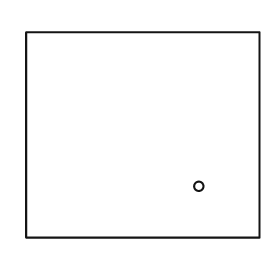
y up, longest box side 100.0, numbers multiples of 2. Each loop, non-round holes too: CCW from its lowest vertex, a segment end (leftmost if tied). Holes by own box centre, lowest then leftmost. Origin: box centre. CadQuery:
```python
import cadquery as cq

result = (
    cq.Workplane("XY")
    .moveTo(-50.0, -44.0)
    .lineTo(50.0, -44.0)
    .lineTo(50.0, 44.0)
    .lineTo(-50.0, 44.0)
    .close()
    .moveTo(24.0, -22.0)
    .circle(2.0)
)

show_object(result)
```